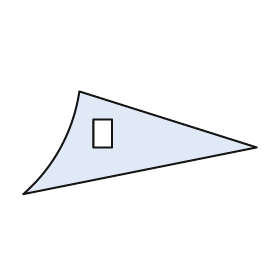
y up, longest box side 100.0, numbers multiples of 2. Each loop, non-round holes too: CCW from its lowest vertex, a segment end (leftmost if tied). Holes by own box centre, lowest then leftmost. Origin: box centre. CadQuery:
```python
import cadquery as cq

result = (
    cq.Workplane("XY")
    .moveTo(-50.0, -22.0)
    .lineTo(50.0, -2.0)
    .lineTo(-26.0, 22.0)
    .threePointArc((-34.0, -2.0), (-50.0, -22.0))
    .close()
    .moveTo(-20.0, -2.0)
    .lineTo(-12.0, -2.0)
    .lineTo(-12.0, 10.0)
    .lineTo(-20.0, 10.0)
    .close()
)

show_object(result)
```